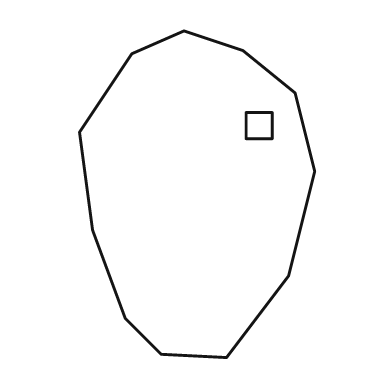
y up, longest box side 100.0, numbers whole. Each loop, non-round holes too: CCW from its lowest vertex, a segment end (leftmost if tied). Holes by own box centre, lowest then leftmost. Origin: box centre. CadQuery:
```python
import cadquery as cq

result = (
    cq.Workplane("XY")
    .moveTo(9.0, -50.0)
    .lineTo(28.0, -25.0)
    .lineTo(36.0, 7.0)
    .lineTo(30.0, 31.0)
    .lineTo(14.0, 44.0)
    .lineTo(-4.0, 50.0)
    .lineTo(-20.0, 43.0)
    .lineTo(-36.0, 19.0)
    .lineTo(-32.0, -11.0)
    .lineTo(-22.0, -38.0)
    .lineTo(-11.0, -49.0)
    .close()
    .moveTo(15.0, 17.0)
    .lineTo(23.0, 17.0)
    .lineTo(23.0, 25.0)
    .lineTo(15.0, 25.0)
    .close()
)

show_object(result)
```